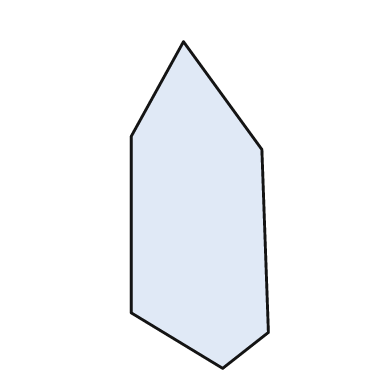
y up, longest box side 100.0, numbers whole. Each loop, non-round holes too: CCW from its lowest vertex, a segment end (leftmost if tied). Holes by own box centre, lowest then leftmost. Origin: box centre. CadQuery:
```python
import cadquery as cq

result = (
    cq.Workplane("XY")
    .moveTo(7.0, -50.0)
    .lineTo(21.0, -39.0)
    .lineTo(19.0, 17.0)
    .lineTo(-5.0, 50.0)
    .lineTo(-21.0, 21.0)
    .lineTo(-21.0, -33.0)
    .close()
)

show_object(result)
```